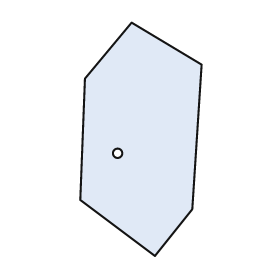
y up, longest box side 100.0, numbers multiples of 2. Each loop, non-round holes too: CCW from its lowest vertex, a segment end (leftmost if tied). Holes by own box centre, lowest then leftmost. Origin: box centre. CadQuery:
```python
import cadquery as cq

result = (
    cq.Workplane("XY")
    .moveTo(6.0, -50.0)
    .lineTo(22.0, -30.0)
    .lineTo(26.0, 32.0)
    .lineTo(-4.0, 50.0)
    .lineTo(-24.0, 26.0)
    .lineTo(-26.0, -26.0)
    .close()
    .moveTo(-10.0, -6.0)
    .circle(2.0)
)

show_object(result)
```